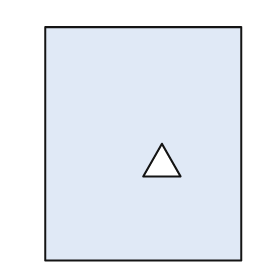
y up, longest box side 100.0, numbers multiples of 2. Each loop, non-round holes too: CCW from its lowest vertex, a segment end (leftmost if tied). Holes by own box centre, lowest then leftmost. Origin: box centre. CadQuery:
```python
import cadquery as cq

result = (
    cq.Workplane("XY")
    .moveTo(-42.0, -50.0)
    .lineTo(42.0, -50.0)
    .lineTo(42.0, 50.0)
    .lineTo(-42.0, 50.0)
    .close()
    .moveTo(0.0, -14.0)
    .lineTo(16.0, -14.0)
    .lineTo(8.0, 0.0)
    .close()
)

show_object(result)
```